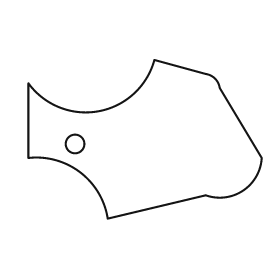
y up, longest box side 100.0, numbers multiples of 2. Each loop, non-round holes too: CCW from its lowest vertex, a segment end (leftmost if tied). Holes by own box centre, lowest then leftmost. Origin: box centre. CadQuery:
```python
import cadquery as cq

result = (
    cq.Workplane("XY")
    .moveTo(-16.0, -34.0)
    .lineTo(26.0, -24.0)
    .threePointArc((42.0, -22.0), (50.0, -8.0))
    .lineTo(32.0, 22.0)
    .threePointArc((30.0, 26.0), (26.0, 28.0))
    .lineTo(4.0, 34.0)
    .threePointArc((-20.0, 12.0), (-50.0, 24.0))
    .lineTo(-50.0, -8.0)
    .threePointArc((-28.0, -14.0), (-16.0, -34.0))
    .close()
    .moveTo(-30.0, -2.0)
    .circle(4.0)
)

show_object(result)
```